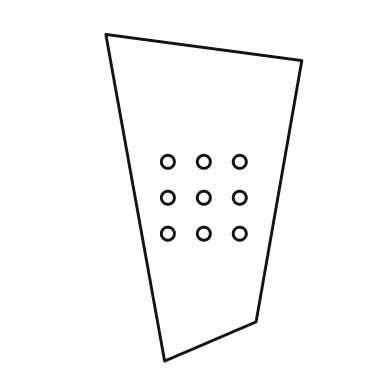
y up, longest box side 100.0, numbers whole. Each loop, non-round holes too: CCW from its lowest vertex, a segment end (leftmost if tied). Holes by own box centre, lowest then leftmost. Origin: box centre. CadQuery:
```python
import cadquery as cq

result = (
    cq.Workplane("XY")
    .moveTo(-12.0, -50.0)
    .lineTo(16.0, -38.0)
    .lineTo(30.0, 42.0)
    .lineTo(-30.0, 50.0)
    .close()
    .moveTo(-11.0, -11.0)
    .circle(2.0)
    .moveTo(0.0, -11.0)
    .circle(2.0)
    .moveTo(11.0, -11.0)
    .circle(2.0)
    .moveTo(-11.0, 0.0)
    .circle(2.0)
    .moveTo(0.0, 0.0)
    .circle(2.0)
    .moveTo(11.0, 0.0)
    .circle(2.0)
    .moveTo(-11.0, 11.0)
    .circle(2.0)
    .moveTo(0.0, 11.0)
    .circle(2.0)
    .moveTo(11.0, 11.0)
    .circle(2.0)
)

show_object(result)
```